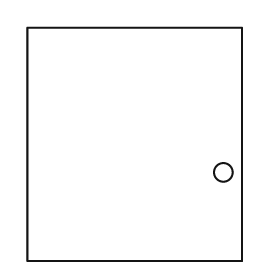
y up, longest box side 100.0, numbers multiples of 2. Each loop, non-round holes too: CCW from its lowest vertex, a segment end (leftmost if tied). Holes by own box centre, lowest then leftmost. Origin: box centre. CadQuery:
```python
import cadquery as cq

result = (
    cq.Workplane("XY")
    .moveTo(-46.0, -50.0)
    .lineTo(46.0, -50.0)
    .lineTo(46.0, 50.0)
    .lineTo(-46.0, 50.0)
    .close()
    .moveTo(38.0, -12.0)
    .circle(4.0)
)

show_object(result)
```